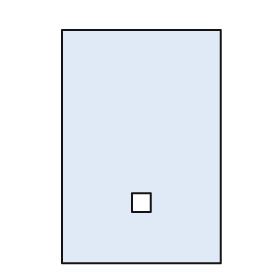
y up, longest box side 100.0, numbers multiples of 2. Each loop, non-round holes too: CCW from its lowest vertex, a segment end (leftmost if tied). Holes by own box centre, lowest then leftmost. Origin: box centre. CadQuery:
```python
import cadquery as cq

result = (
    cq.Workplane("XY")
    .moveTo(-34.0, -50.0)
    .lineTo(34.0, -50.0)
    .lineTo(34.0, 50.0)
    .lineTo(-34.0, 50.0)
    .close()
    .moveTo(-4.0, -28.0)
    .lineTo(4.0, -28.0)
    .lineTo(4.0, -20.0)
    .lineTo(-4.0, -20.0)
    .close()
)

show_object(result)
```